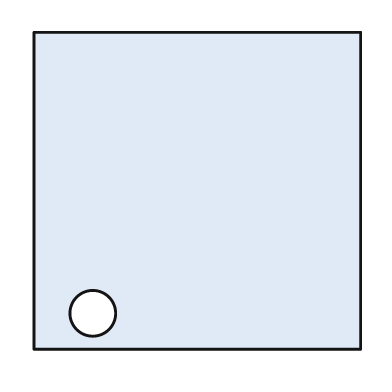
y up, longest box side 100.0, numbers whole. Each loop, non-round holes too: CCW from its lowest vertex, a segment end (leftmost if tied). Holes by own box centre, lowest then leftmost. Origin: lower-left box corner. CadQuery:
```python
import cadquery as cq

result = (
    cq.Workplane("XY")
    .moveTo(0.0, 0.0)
    .lineTo(100.0, 0.0)
    .lineTo(100.0, 97.0)
    .lineTo(0.0, 97.0)
    .close()
    .moveTo(18.0, 11.0)
    .circle(7.0)
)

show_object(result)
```